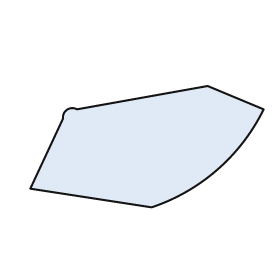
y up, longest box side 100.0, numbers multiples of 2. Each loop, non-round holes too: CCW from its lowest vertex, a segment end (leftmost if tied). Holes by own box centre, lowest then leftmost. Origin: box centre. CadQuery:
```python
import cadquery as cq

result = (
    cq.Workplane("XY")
    .moveTo(2.0, -26.0)
    .threePointArc((30.0, -10.0), (50.0, 16.0))
    .lineTo(26.0, 26.0)
    .lineTo(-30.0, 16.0)
    .threePointArc((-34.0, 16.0), (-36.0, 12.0))
    .lineTo(-50.0, -18.0)
    .close()
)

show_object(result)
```